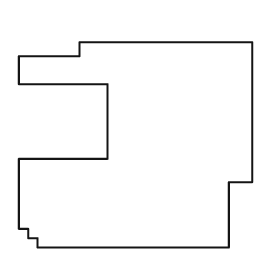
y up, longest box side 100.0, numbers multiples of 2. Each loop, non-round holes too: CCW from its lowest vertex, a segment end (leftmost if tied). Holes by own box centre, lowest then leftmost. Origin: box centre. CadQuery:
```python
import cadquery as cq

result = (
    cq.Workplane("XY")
    .moveTo(-42.0, -44.0)
    .lineTo(40.0, -44.0)
    .lineTo(40.0, -16.0)
    .lineTo(50.0, -16.0)
    .lineTo(50.0, 44.0)
    .lineTo(-24.0, 44.0)
    .lineTo(-24.0, 38.0)
    .lineTo(-50.0, 38.0)
    .lineTo(-50.0, 26.0)
    .lineTo(-12.0, 26.0)
    .lineTo(-12.0, -6.0)
    .lineTo(-50.0, -6.0)
    .lineTo(-50.0, -36.0)
    .lineTo(-46.0, -36.0)
    .lineTo(-46.0, -40.0)
    .lineTo(-42.0, -40.0)
    .close()
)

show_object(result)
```